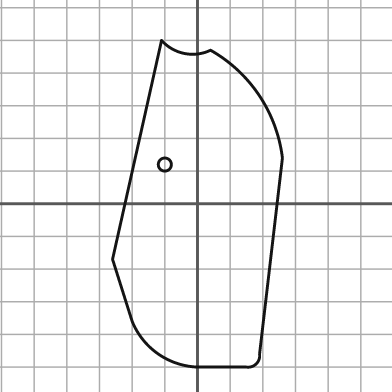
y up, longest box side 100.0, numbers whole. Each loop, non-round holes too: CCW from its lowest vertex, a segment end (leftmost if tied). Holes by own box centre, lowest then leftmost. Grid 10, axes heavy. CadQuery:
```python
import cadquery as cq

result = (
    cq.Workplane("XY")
    .moveTo(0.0, -50.0)
    .lineTo(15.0, -50.0)
    .threePointArc((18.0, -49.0), (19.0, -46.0))
    .lineTo(26.0, 14.0)
    .threePointArc((19.0, 33.0), (4.0, 47.0))
    .threePointArc((-4.0, 46.0), (-11.0, 50.0))
    .lineTo(-26.0, -17.0)
    .lineTo(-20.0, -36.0)
    .threePointArc((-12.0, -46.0), (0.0, -50.0))
    .close()
    .moveTo(-10.0, 12.0)
    .circle(2.0)
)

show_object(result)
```